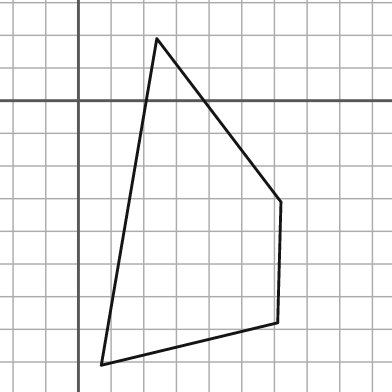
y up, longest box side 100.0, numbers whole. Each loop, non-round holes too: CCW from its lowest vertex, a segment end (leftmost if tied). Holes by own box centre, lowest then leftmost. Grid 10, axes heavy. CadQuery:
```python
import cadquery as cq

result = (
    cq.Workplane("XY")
    .moveTo(7.0, -81.0)
    .lineTo(61.0, -68.0)
    .lineTo(62.0, -31.0)
    .lineTo(24.0, 19.0)
    .close()
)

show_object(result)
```